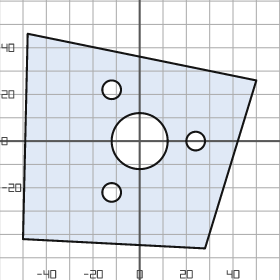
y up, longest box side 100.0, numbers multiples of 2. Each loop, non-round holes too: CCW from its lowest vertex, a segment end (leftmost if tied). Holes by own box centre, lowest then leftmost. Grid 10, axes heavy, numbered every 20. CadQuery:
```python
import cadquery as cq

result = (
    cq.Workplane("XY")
    .moveTo(28.0, -46.0)
    .lineTo(50.0, 26.0)
    .lineTo(-48.0, 46.0)
    .lineTo(-50.0, -42.0)
    .close()
    .moveTo(-12.0, -22.0)
    .circle(4.0)
    .moveTo(0.0, 0.0)
    .circle(12.0)
    .moveTo(24.0, 0.0)
    .circle(4.0)
    .moveTo(-12.0, 22.0)
    .circle(4.0)
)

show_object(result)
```